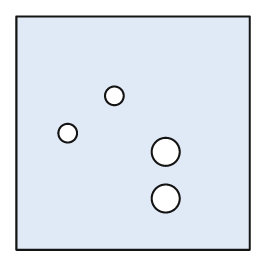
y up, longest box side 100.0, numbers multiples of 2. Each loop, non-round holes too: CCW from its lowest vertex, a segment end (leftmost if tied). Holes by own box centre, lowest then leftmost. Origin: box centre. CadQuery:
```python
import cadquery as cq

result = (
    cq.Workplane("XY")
    .moveTo(-50.0, -50.0)
    .lineTo(50.0, -50.0)
    .lineTo(50.0, 50.0)
    .lineTo(-50.0, 50.0)
    .close()
    .moveTo(14.0, -28.0)
    .circle(6.0)
    .moveTo(14.0, -8.0)
    .circle(6.0)
    .moveTo(-28.0, 0.0)
    .circle(4.0)
    .moveTo(-8.0, 16.0)
    .circle(4.0)
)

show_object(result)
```